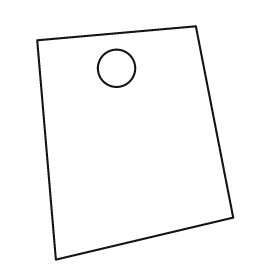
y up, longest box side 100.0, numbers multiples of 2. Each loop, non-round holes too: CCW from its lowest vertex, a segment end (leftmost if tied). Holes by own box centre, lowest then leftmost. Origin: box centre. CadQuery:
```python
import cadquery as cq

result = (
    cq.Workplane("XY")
    .moveTo(-34.0, -50.0)
    .lineTo(42.0, -32.0)
    .lineTo(26.0, 50.0)
    .lineTo(-42.0, 44.0)
    .close()
    .moveTo(-8.0, 32.0)
    .circle(8.0)
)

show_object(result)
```